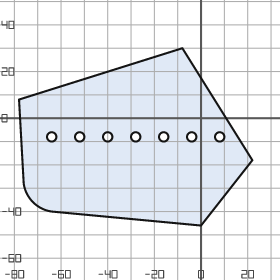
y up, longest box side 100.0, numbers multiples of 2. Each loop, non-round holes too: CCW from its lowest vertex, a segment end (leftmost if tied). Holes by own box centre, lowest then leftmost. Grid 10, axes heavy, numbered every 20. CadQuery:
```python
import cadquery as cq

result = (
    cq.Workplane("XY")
    .moveTo(0.0, -46.0)
    .lineTo(22.0, -18.0)
    .lineTo(-8.0, 30.0)
    .lineTo(-78.0, 8.0)
    .lineTo(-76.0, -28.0)
    .threePointArc((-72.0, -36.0), (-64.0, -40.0))
    .close()
    .moveTo(-64.0, -8.0)
    .circle(2.0)
    .moveTo(-52.0, -8.0)
    .circle(2.0)
    .moveTo(-40.0, -8.0)
    .circle(2.0)
    .moveTo(-28.0, -8.0)
    .circle(2.0)
    .moveTo(-16.0, -8.0)
    .circle(2.0)
    .moveTo(-4.0, -8.0)
    .circle(2.0)
    .moveTo(8.0, -8.0)
    .circle(2.0)
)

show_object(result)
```